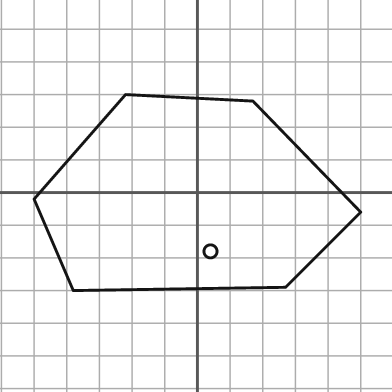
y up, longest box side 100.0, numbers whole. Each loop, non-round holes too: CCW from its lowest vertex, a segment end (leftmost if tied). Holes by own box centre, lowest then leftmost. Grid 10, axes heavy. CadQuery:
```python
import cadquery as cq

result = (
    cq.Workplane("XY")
    .moveTo(-38.0, -30.0)
    .lineTo(27.0, -29.0)
    .lineTo(50.0, -6.0)
    .lineTo(17.0, 28.0)
    .lineTo(-22.0, 30.0)
    .lineTo(-50.0, -2.0)
    .close()
    .moveTo(4.0, -18.0)
    .circle(2.0)
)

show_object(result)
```